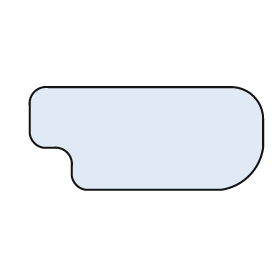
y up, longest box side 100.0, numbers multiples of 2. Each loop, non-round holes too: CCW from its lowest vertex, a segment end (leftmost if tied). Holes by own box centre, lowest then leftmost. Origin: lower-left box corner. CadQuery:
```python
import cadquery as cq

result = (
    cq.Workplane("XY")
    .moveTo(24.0, 0.0)
    .lineTo(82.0, 0.0)
    .threePointArc((94.0, 6.0), (100.0, 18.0))
    .lineTo(100.0, 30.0)
    .threePointArc((96.0, 40.0), (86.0, 44.0))
    .lineTo(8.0, 44.0)
    .threePointArc((2.0, 42.0), (0.0, 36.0))
    .lineTo(0.0, 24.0)
    .threePointArc((2.0, 20.0), (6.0, 18.0))
    .lineTo(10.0, 18.0)
    .threePointArc((16.0, 16.0), (18.0, 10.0))
    .lineTo(18.0, 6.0)
    .threePointArc((20.0, 2.0), (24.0, 0.0))
    .close()
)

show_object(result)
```